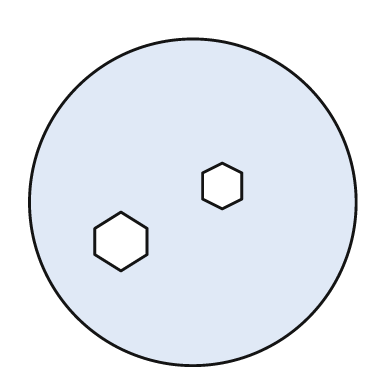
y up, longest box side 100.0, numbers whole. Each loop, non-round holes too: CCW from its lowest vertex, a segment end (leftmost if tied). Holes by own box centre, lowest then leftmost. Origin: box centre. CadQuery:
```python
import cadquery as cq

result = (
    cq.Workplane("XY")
    .moveTo(0.0, 0.0)
    .circle(50.0)
    .moveTo(-22.0, -21.0)
    .lineTo(-14.0, -16.0)
    .lineTo(-14.0, -8.0)
    .lineTo(-22.0, -3.0)
    .lineTo(-30.0, -8.0)
    .lineTo(-30.0, -16.0)
    .close()
    .moveTo(9.0, -2.0)
    .lineTo(15.0, 1.0)
    .lineTo(15.0, 9.0)
    .lineTo(9.0, 12.0)
    .lineTo(3.0, 9.0)
    .lineTo(3.0, 1.0)
    .close()
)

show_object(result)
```